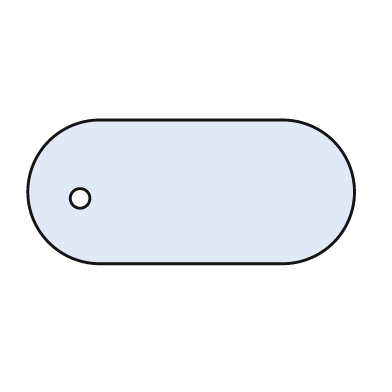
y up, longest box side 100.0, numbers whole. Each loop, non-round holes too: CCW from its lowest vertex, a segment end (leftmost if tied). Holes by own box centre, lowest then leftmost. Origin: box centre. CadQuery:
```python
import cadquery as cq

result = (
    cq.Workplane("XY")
    .moveTo(-28.0, -22.0)
    .lineTo(28.0, -22.0)
    .threePointArc((50.0, 0.0), (28.0, 22.0))
    .lineTo(-28.0, 22.0)
    .threePointArc((-50.0, 0.0), (-28.0, -22.0))
    .close()
    .moveTo(-34.0, -2.0)
    .circle(3.0)
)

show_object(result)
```